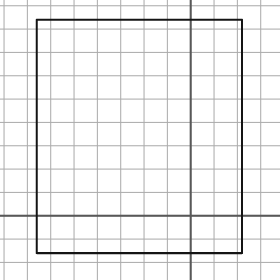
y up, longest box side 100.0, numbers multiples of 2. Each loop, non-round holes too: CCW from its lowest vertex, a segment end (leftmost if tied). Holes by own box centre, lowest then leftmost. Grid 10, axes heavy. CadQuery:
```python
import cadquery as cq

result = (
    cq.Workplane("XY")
    .moveTo(-66.0, -16.0)
    .lineTo(22.0, -16.0)
    .lineTo(22.0, 84.0)
    .lineTo(-66.0, 84.0)
    .close()
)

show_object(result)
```